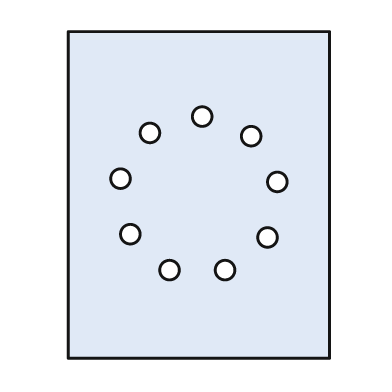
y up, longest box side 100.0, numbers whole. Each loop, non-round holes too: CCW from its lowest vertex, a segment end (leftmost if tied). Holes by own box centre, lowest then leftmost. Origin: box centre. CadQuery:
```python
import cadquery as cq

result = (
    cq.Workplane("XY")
    .moveTo(-40.0, -50.0)
    .lineTo(40.0, -50.0)
    .lineTo(40.0, 50.0)
    .lineTo(-40.0, 50.0)
    .close()
    .moveTo(-9.0, -23.0)
    .circle(3.0)
    .moveTo(8.0, -23.0)
    .circle(3.0)
    .moveTo(21.0, -13.0)
    .circle(3.0)
    .moveTo(-21.0, -12.0)
    .circle(3.0)
    .moveTo(24.0, 4.0)
    .circle(3.0)
    .moveTo(-24.0, 5.0)
    .circle(3.0)
    .moveTo(16.0, 18.0)
    .circle(3.0)
    .moveTo(-15.0, 19.0)
    .circle(3.0)
    .moveTo(1.0, 24.0)
    .circle(3.0)
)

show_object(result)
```